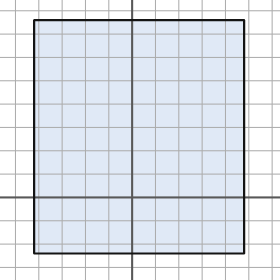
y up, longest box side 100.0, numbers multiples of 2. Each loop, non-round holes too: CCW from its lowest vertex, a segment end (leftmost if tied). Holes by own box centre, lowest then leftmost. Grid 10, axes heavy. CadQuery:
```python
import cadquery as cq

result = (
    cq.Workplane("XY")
    .moveTo(-42.0, -24.0)
    .lineTo(48.0, -24.0)
    .lineTo(48.0, 76.0)
    .lineTo(-42.0, 76.0)
    .close()
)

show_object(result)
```